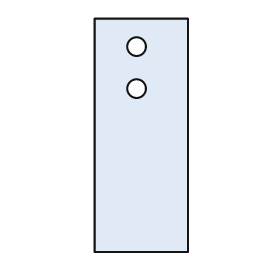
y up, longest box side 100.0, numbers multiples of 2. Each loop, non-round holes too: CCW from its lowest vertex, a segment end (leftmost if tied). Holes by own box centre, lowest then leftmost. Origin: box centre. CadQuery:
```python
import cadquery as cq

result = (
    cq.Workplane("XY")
    .moveTo(-20.0, -50.0)
    .lineTo(20.0, -50.0)
    .lineTo(20.0, 50.0)
    .lineTo(-20.0, 50.0)
    .close()
    .moveTo(-2.0, 20.0)
    .circle(4.0)
    .moveTo(-2.0, 38.0)
    .circle(4.0)
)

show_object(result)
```